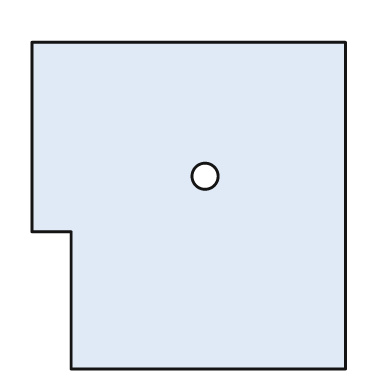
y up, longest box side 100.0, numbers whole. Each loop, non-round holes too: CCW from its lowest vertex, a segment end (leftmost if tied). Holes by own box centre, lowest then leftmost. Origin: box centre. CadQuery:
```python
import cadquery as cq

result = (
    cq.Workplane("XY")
    .moveTo(-36.0, -50.0)
    .lineTo(48.0, -50.0)
    .lineTo(48.0, 50.0)
    .lineTo(-48.0, 50.0)
    .lineTo(-48.0, -8.0)
    .lineTo(-36.0, -8.0)
    .close()
    .moveTo(5.0, 9.0)
    .circle(4.0)
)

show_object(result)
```